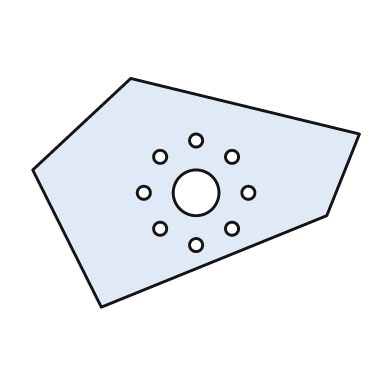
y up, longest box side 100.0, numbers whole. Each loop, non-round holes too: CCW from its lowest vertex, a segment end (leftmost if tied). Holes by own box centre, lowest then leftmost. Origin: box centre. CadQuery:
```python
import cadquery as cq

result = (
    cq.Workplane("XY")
    .moveTo(-29.0, -35.0)
    .lineTo(40.0, -7.0)
    .lineTo(50.0, 18.0)
    .lineTo(-20.0, 35.0)
    .lineTo(-50.0, 7.0)
    .close()
    .moveTo(0.0, -16.0)
    .circle(2.0)
    .moveTo(-11.0, -11.0)
    .circle(2.0)
    .moveTo(11.0, -11.0)
    .circle(2.0)
    .moveTo(-16.0, 0.0)
    .circle(2.0)
    .moveTo(0.0, 0.0)
    .circle(7.0)
    .moveTo(16.0, 0.0)
    .circle(2.0)
    .moveTo(-11.0, 11.0)
    .circle(2.0)
    .moveTo(11.0, 11.0)
    .circle(2.0)
    .moveTo(0.0, 16.0)
    .circle(2.0)
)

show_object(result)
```